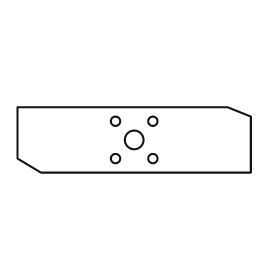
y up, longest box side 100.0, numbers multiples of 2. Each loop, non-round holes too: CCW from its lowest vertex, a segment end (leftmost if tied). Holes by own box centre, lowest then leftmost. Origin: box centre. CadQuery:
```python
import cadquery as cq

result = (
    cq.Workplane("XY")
    .moveTo(-40.0, -14.0)
    .lineTo(50.0, -14.0)
    .lineTo(50.0, 10.0)
    .lineTo(40.0, 14.0)
    .lineTo(-50.0, 14.0)
    .lineTo(-50.0, -8.0)
    .close()
    .moveTo(-8.0, -8.0)
    .circle(2.0)
    .moveTo(8.0, -8.0)
    .circle(2.0)
    .moveTo(0.0, 0.0)
    .circle(4.0)
    .moveTo(-8.0, 8.0)
    .circle(2.0)
    .moveTo(8.0, 8.0)
    .circle(2.0)
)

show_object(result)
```